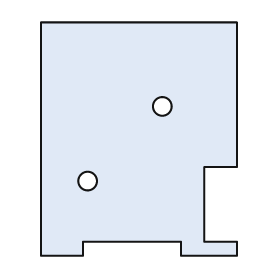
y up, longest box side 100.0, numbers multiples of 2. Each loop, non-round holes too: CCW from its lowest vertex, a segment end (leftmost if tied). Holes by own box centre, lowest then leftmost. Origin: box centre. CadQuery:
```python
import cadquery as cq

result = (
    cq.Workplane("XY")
    .moveTo(-42.0, -50.0)
    .lineTo(-24.0, -50.0)
    .lineTo(-24.0, -44.0)
    .lineTo(18.0, -44.0)
    .lineTo(18.0, -50.0)
    .lineTo(42.0, -50.0)
    .lineTo(42.0, -44.0)
    .lineTo(28.0, -44.0)
    .lineTo(28.0, -12.0)
    .lineTo(42.0, -12.0)
    .lineTo(42.0, 50.0)
    .lineTo(-42.0, 50.0)
    .close()
    .moveTo(-22.0, -18.0)
    .circle(4.0)
    .moveTo(10.0, 14.0)
    .circle(4.0)
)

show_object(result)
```